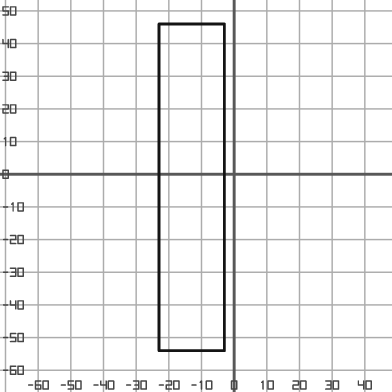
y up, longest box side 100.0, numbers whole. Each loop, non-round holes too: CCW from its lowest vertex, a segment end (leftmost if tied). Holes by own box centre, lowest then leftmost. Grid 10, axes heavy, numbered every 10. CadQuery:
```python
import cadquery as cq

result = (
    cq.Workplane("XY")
    .moveTo(-23.0, -54.0)
    .lineTo(-3.0, -54.0)
    .lineTo(-3.0, 46.0)
    .lineTo(-23.0, 46.0)
    .close()
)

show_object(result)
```